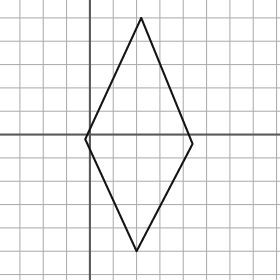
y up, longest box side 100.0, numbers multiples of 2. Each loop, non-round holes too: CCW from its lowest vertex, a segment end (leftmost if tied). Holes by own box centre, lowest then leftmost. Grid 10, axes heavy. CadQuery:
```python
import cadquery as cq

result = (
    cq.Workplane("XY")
    .moveTo(20.0, -50.0)
    .lineTo(44.0, -4.0)
    .lineTo(22.0, 50.0)
    .lineTo(-2.0, -2.0)
    .close()
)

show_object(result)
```